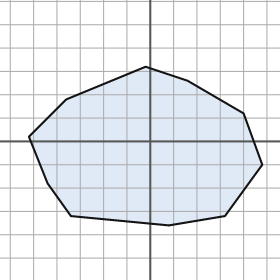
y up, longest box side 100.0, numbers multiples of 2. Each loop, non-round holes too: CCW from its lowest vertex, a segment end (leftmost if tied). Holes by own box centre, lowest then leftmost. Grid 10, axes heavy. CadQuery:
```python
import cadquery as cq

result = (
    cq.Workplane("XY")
    .moveTo(8.0, -36.0)
    .lineTo(32.0, -32.0)
    .lineTo(48.0, -10.0)
    .lineTo(40.0, 12.0)
    .lineTo(16.0, 26.0)
    .lineTo(-2.0, 32.0)
    .lineTo(-36.0, 18.0)
    .lineTo(-52.0, 2.0)
    .lineTo(-44.0, -18.0)
    .lineTo(-34.0, -32.0)
    .close()
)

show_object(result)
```